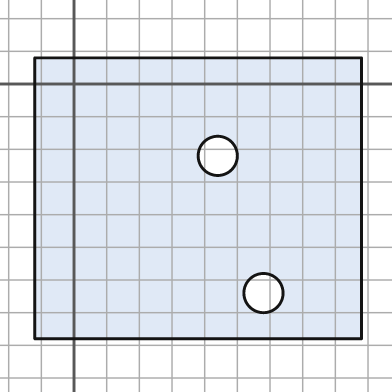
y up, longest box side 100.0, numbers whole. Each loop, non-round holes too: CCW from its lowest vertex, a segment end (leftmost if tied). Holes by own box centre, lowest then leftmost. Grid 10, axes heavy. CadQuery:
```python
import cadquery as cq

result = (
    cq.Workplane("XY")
    .moveTo(-12.0, -78.0)
    .lineTo(88.0, -78.0)
    .lineTo(88.0, 8.0)
    .lineTo(-12.0, 8.0)
    .close()
    .moveTo(58.0, -64.0)
    .circle(6.0)
    .moveTo(44.0, -22.0)
    .circle(6.0)
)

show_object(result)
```